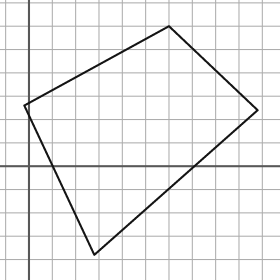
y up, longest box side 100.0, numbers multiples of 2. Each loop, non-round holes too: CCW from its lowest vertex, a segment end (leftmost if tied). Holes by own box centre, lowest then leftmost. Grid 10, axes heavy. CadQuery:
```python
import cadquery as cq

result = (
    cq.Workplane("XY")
    .moveTo(28.0, -38.0)
    .lineTo(98.0, 24.0)
    .lineTo(60.0, 60.0)
    .lineTo(-2.0, 26.0)
    .close()
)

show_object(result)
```